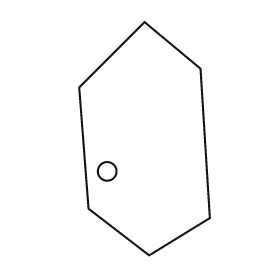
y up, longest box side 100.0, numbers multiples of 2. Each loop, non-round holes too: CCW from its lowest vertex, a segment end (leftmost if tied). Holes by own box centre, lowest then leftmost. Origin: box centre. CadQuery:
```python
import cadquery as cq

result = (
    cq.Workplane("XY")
    .moveTo(2.0, -50.0)
    .lineTo(28.0, -34.0)
    .lineTo(24.0, 30.0)
    .lineTo(0.0, 50.0)
    .lineTo(-28.0, 22.0)
    .lineTo(-24.0, -30.0)
    .close()
    .moveTo(-16.0, -14.0)
    .circle(4.0)
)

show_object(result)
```